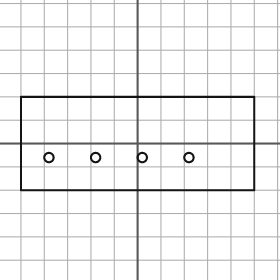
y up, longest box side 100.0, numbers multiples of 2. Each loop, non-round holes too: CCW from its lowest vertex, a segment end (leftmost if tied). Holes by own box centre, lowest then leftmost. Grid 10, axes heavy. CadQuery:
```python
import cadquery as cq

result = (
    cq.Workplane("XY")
    .moveTo(-50.0, -20.0)
    .lineTo(50.0, -20.0)
    .lineTo(50.0, 20.0)
    .lineTo(-50.0, 20.0)
    .close()
    .moveTo(-38.0, -6.0)
    .circle(2.0)
    .moveTo(-18.0, -6.0)
    .circle(2.0)
    .moveTo(2.0, -6.0)
    .circle(2.0)
    .moveTo(22.0, -6.0)
    .circle(2.0)
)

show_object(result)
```